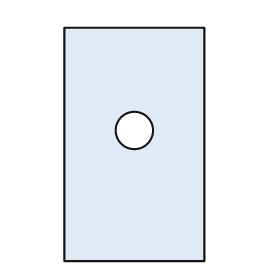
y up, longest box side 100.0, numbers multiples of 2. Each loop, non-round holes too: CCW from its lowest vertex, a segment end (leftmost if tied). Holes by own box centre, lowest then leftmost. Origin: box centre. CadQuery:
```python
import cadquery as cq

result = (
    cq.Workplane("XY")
    .moveTo(-30.0, -50.0)
    .lineTo(30.0, -50.0)
    .lineTo(30.0, 50.0)
    .lineTo(-30.0, 50.0)
    .close()
    .moveTo(0.0, 6.0)
    .circle(8.0)
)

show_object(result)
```